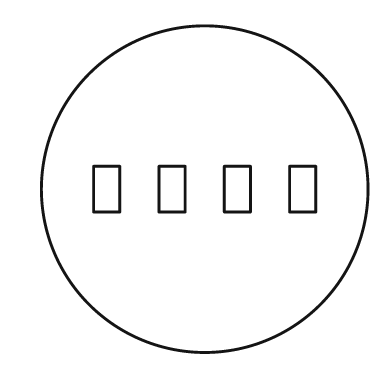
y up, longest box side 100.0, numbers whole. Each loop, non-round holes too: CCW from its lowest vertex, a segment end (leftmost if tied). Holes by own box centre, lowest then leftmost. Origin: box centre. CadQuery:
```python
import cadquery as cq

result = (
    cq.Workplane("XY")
    .moveTo(0.0, 0.0)
    .circle(50.0)
    .moveTo(-34.0, -7.0)
    .lineTo(-26.0, -7.0)
    .lineTo(-26.0, 7.0)
    .lineTo(-34.0, 7.0)
    .close()
    .moveTo(-14.0, -7.0)
    .lineTo(-6.0, -7.0)
    .lineTo(-6.0, 7.0)
    .lineTo(-14.0, 7.0)
    .close()
    .moveTo(6.0, -7.0)
    .lineTo(14.0, -7.0)
    .lineTo(14.0, 7.0)
    .lineTo(6.0, 7.0)
    .close()
    .moveTo(26.0, -7.0)
    .lineTo(34.0, -7.0)
    .lineTo(34.0, 7.0)
    .lineTo(26.0, 7.0)
    .close()
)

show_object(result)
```